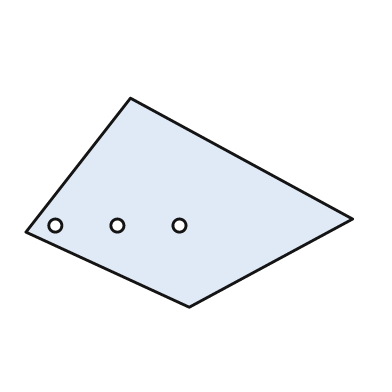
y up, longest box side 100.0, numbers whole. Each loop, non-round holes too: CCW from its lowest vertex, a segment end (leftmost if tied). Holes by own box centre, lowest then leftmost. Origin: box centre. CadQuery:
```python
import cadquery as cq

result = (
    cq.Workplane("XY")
    .moveTo(0.0, -32.0)
    .lineTo(50.0, -5.0)
    .lineTo(-18.0, 32.0)
    .lineTo(-50.0, -9.0)
    .close()
    .moveTo(-41.0, -7.0)
    .circle(2.0)
    .moveTo(-22.0, -7.0)
    .circle(2.0)
    .moveTo(-3.0, -7.0)
    .circle(2.0)
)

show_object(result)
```